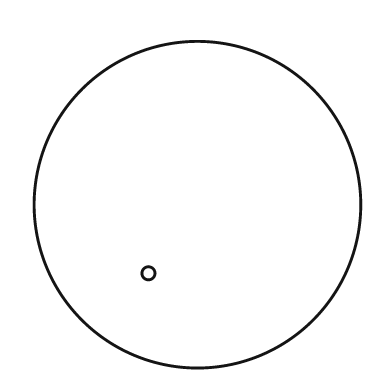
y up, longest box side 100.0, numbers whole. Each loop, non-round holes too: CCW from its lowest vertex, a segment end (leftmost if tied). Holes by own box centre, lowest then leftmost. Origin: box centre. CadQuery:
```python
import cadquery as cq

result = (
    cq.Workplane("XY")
    .moveTo(0.0, 0.0)
    .circle(50.0)
    .moveTo(-15.0, -21.0)
    .circle(2.0)
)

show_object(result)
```